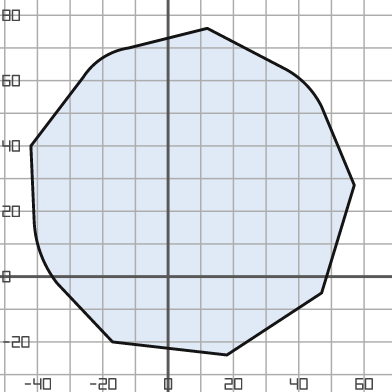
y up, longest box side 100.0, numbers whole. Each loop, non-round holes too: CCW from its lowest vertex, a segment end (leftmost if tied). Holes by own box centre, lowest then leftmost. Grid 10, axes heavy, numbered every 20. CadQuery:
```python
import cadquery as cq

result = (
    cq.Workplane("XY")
    .moveTo(18.0, -24.0)
    .lineTo(47.0, -5.0)
    .lineTo(57.0, 28.0)
    .lineTo(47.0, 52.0)
    .threePointArc((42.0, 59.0), (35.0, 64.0))
    .lineTo(12.0, 76.0)
    .lineTo(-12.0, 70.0)
    .threePointArc((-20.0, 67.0), (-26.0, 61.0))
    .lineTo(-42.0, 40.0)
    .lineTo(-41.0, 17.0)
    .threePointArc((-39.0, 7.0), (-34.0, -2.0))
    .lineTo(-17.0, -20.0)
    .close()
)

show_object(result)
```